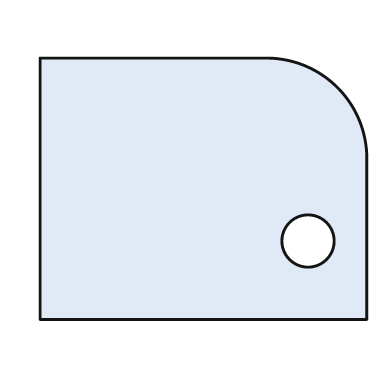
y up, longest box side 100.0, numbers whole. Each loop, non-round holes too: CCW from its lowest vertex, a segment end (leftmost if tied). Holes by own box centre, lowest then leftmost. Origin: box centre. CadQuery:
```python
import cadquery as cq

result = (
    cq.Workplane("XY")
    .moveTo(-50.0, -40.0)
    .lineTo(50.0, -40.0)
    .lineTo(50.0, 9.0)
    .threePointArc((41.0, 31.0), (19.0, 40.0))
    .lineTo(-50.0, 40.0)
    .close()
    .moveTo(32.0, -16.0)
    .circle(8.0)
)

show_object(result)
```